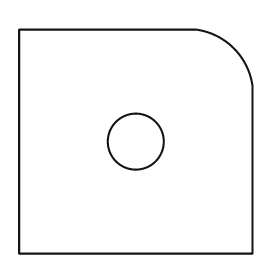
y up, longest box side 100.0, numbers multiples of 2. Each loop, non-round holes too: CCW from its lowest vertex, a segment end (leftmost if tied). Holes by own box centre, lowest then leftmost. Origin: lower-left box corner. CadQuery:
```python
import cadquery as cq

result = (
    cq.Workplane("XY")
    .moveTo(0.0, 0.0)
    .lineTo(100.0, 0.0)
    .lineTo(100.0, 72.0)
    .threePointArc((92.0, 88.0), (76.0, 96.0))
    .lineTo(0.0, 96.0)
    .close()
    .moveTo(50.0, 48.0)
    .circle(12.0)
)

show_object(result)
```